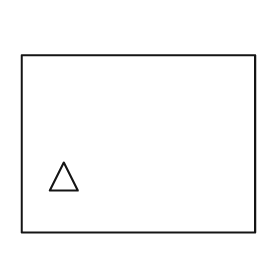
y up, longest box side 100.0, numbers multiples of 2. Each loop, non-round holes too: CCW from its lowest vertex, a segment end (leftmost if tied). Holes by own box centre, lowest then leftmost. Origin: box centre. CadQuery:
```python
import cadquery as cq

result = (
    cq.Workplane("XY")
    .moveTo(-50.0, -38.0)
    .lineTo(50.0, -38.0)
    .lineTo(50.0, 38.0)
    .lineTo(-50.0, 38.0)
    .close()
    .moveTo(-38.0, -20.0)
    .lineTo(-26.0, -20.0)
    .lineTo(-32.0, -8.0)
    .close()
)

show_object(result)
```